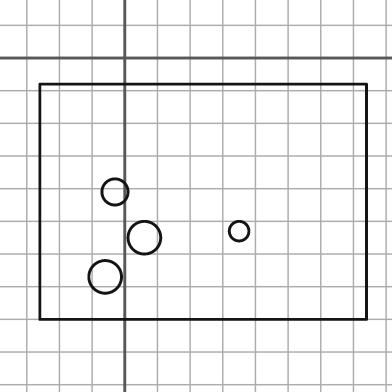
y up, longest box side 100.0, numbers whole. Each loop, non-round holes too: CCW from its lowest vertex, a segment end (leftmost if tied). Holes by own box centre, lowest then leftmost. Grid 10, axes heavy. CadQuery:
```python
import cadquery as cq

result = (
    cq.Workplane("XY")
    .moveTo(-26.0, -80.0)
    .lineTo(74.0, -80.0)
    .lineTo(74.0, -8.0)
    .lineTo(-26.0, -8.0)
    .close()
    .moveTo(-6.0, -67.0)
    .circle(5.0)
    .moveTo(6.0, -55.0)
    .circle(5.0)
    .moveTo(35.0, -53.0)
    .circle(3.0)
    .moveTo(-3.0, -41.0)
    .circle(4.0)
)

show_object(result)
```